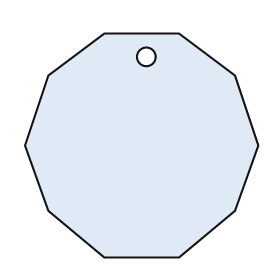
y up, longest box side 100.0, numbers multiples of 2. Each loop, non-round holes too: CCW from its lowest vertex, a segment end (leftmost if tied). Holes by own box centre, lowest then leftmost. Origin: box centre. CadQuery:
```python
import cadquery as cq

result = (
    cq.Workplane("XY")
    .moveTo(-16.0, -48.0)
    .lineTo(16.0, -48.0)
    .lineTo(40.0, -28.0)
    .lineTo(50.0, 0.0)
    .lineTo(40.0, 30.0)
    .lineTo(16.0, 48.0)
    .lineTo(-16.0, 48.0)
    .lineTo(-40.0, 30.0)
    .lineTo(-50.0, 0.0)
    .lineTo(-40.0, -28.0)
    .close()
    .moveTo(2.0, 38.0)
    .circle(4.0)
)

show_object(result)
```